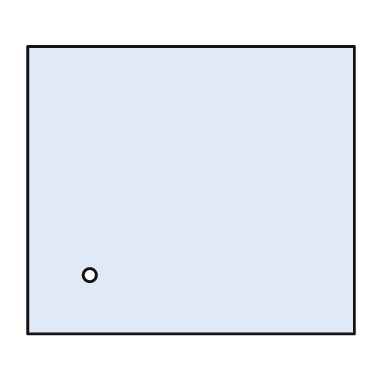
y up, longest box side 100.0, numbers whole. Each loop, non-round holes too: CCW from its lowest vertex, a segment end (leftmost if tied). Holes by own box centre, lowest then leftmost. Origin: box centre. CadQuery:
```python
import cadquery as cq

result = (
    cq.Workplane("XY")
    .moveTo(-50.0, -44.0)
    .lineTo(50.0, -44.0)
    .lineTo(50.0, 44.0)
    .lineTo(-50.0, 44.0)
    .close()
    .moveTo(-31.0, -26.0)
    .circle(2.0)
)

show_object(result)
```